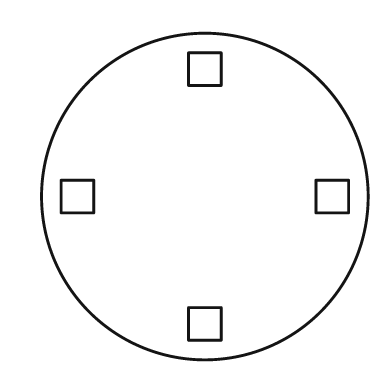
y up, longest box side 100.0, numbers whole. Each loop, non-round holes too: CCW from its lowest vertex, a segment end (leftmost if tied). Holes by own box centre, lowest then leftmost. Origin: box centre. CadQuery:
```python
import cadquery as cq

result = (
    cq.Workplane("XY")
    .moveTo(0.0, 0.0)
    .circle(50.0)
    .moveTo(-5.0, -44.0)
    .lineTo(5.0, -44.0)
    .lineTo(5.0, -34.0)
    .lineTo(-5.0, -34.0)
    .close()
    .moveTo(-44.0, -5.0)
    .lineTo(-34.0, -5.0)
    .lineTo(-34.0, 5.0)
    .lineTo(-44.0, 5.0)
    .close()
    .moveTo(34.0, -5.0)
    .lineTo(44.0, -5.0)
    .lineTo(44.0, 5.0)
    .lineTo(34.0, 5.0)
    .close()
    .moveTo(-5.0, 34.0)
    .lineTo(5.0, 34.0)
    .lineTo(5.0, 44.0)
    .lineTo(-5.0, 44.0)
    .close()
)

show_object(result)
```